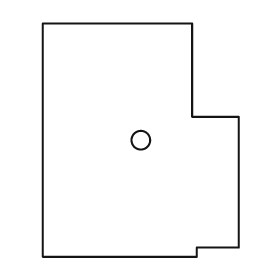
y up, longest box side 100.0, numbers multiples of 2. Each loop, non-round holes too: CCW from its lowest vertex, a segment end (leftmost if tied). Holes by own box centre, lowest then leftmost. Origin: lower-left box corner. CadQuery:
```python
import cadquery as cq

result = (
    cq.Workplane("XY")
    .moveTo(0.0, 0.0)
    .lineTo(66.0, 0.0)
    .lineTo(66.0, 4.0)
    .lineTo(84.0, 4.0)
    .lineTo(84.0, 60.0)
    .lineTo(64.0, 60.0)
    .lineTo(64.0, 100.0)
    .lineTo(0.0, 100.0)
    .close()
    .moveTo(42.0, 50.0)
    .circle(4.0)
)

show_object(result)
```